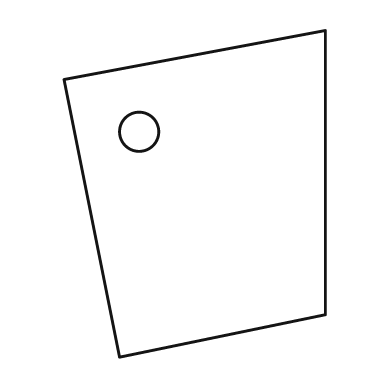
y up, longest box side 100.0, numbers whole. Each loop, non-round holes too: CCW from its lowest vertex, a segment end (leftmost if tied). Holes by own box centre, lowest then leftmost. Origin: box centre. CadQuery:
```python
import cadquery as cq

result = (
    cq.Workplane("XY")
    .moveTo(-23.0, -50.0)
    .lineTo(40.0, -37.0)
    .lineTo(40.0, 50.0)
    .lineTo(-40.0, 35.0)
    .close()
    .moveTo(-17.0, 19.0)
    .circle(6.0)
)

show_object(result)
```